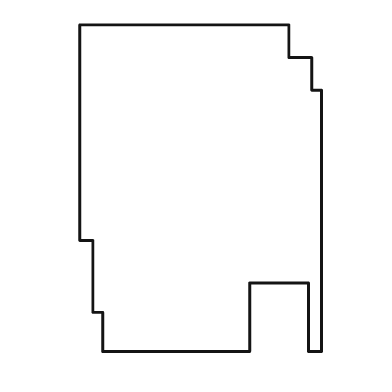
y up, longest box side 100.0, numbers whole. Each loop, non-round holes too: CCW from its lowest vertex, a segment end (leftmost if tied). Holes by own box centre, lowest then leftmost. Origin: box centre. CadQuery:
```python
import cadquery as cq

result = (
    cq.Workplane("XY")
    .moveTo(-30.0, -50.0)
    .lineTo(15.0, -50.0)
    .lineTo(15.0, -29.0)
    .lineTo(33.0, -29.0)
    .lineTo(33.0, -50.0)
    .lineTo(37.0, -50.0)
    .lineTo(37.0, 30.0)
    .lineTo(34.0, 30.0)
    .lineTo(34.0, 40.0)
    .lineTo(27.0, 40.0)
    .lineTo(27.0, 50.0)
    .lineTo(-37.0, 50.0)
    .lineTo(-37.0, -16.0)
    .lineTo(-33.0, -16.0)
    .lineTo(-33.0, -38.0)
    .lineTo(-30.0, -38.0)
    .close()
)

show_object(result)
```